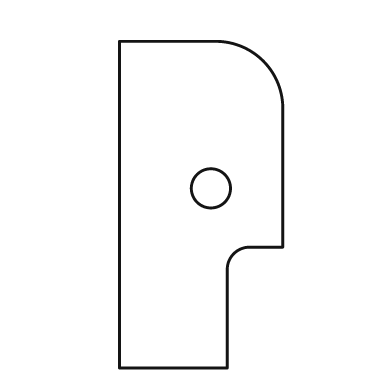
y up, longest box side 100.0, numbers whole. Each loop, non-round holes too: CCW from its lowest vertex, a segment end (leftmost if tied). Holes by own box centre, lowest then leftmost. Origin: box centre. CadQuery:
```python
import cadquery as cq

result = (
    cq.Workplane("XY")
    .moveTo(-25.0, -50.0)
    .lineTo(8.0, -50.0)
    .lineTo(8.0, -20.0)
    .threePointArc((10.0, -15.0), (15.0, -13.0))
    .lineTo(25.0, -13.0)
    .lineTo(25.0, 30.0)
    .threePointArc((19.0, 44.0), (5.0, 50.0))
    .lineTo(-25.0, 50.0)
    .close()
    .moveTo(3.0, 5.0)
    .circle(6.0)
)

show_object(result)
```